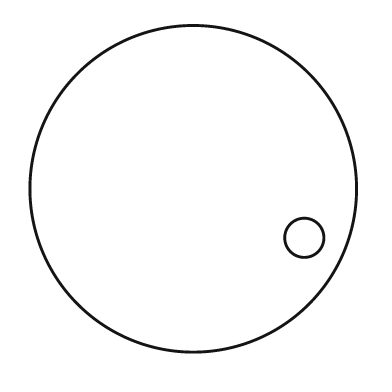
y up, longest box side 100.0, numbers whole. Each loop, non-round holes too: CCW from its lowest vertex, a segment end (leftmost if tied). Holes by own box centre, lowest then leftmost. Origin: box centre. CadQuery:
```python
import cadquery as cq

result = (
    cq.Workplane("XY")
    .moveTo(0.0, 0.0)
    .circle(50.0)
    .moveTo(34.0, -15.0)
    .circle(6.0)
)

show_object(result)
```